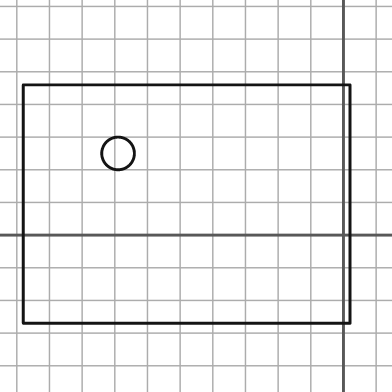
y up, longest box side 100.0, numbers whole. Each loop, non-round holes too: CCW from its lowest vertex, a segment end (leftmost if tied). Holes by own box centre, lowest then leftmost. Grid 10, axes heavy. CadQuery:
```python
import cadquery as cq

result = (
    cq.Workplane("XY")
    .moveTo(-98.0, -27.0)
    .lineTo(2.0, -27.0)
    .lineTo(2.0, 46.0)
    .lineTo(-98.0, 46.0)
    .close()
    .moveTo(-69.0, 25.0)
    .circle(5.0)
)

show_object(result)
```